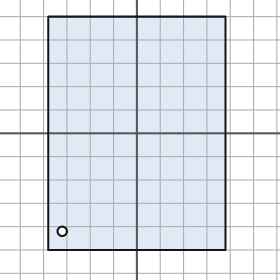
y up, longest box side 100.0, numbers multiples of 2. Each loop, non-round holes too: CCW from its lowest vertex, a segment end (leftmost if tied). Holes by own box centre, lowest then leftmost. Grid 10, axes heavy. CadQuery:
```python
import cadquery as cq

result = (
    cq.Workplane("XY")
    .moveTo(-38.0, -50.0)
    .lineTo(38.0, -50.0)
    .lineTo(38.0, 50.0)
    .lineTo(-38.0, 50.0)
    .close()
    .moveTo(-32.0, -42.0)
    .circle(2.0)
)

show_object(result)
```